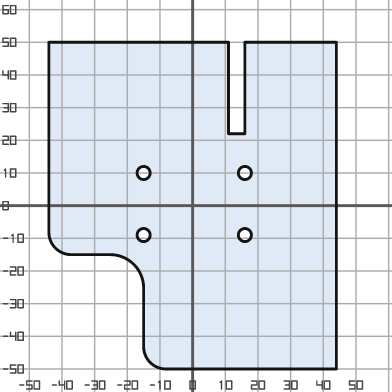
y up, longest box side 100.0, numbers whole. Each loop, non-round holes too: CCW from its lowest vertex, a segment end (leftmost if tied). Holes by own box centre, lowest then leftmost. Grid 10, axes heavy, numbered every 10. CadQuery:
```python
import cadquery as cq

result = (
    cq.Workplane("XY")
    .moveTo(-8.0, -50.0)
    .lineTo(44.0, -50.0)
    .lineTo(44.0, 50.0)
    .lineTo(16.0, 50.0)
    .lineTo(16.0, 22.0)
    .lineTo(11.0, 22.0)
    .lineTo(11.0, 50.0)
    .lineTo(-44.0, 50.0)
    .lineTo(-44.0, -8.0)
    .threePointArc((-42.0, -13.0), (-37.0, -15.0))
    .lineTo(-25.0, -15.0)
    .threePointArc((-18.0, -18.0), (-15.0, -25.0))
    .lineTo(-15.0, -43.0)
    .threePointArc((-13.0, -48.0), (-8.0, -50.0))
    .close()
    .moveTo(-15.0, -9.0)
    .circle(2.0)
    .moveTo(16.0, -9.0)
    .circle(2.0)
    .moveTo(-15.0, 10.0)
    .circle(2.0)
    .moveTo(16.0, 10.0)
    .circle(2.0)
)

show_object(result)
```